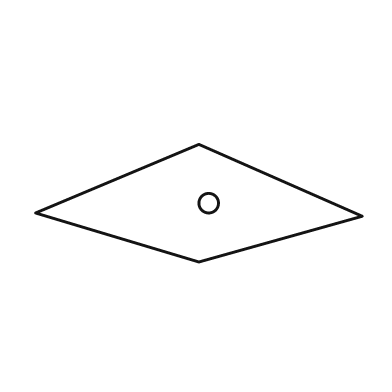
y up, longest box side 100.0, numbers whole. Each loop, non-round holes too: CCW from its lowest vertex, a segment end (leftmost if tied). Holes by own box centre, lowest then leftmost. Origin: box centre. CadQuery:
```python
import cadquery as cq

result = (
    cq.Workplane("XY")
    .moveTo(0.0, -18.0)
    .lineTo(50.0, -4.0)
    .lineTo(0.0, 18.0)
    .lineTo(-50.0, -3.0)
    .close()
    .moveTo(3.0, 0.0)
    .circle(3.0)
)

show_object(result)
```